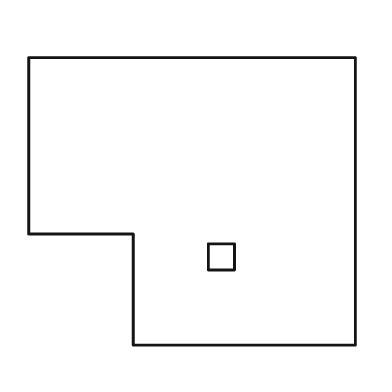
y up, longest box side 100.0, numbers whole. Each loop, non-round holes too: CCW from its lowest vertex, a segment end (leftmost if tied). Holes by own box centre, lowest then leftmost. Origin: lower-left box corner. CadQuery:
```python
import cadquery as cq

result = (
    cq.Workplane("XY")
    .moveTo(32.0, 0.0)
    .lineTo(100.0, 0.0)
    .lineTo(100.0, 88.0)
    .lineTo(0.0, 88.0)
    .lineTo(0.0, 34.0)
    .lineTo(32.0, 34.0)
    .close()
    .moveTo(55.0, 23.0)
    .lineTo(63.0, 23.0)
    .lineTo(63.0, 31.0)
    .lineTo(55.0, 31.0)
    .close()
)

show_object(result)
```